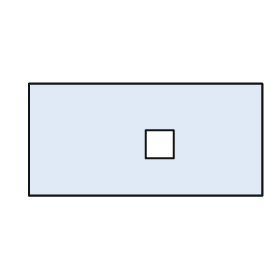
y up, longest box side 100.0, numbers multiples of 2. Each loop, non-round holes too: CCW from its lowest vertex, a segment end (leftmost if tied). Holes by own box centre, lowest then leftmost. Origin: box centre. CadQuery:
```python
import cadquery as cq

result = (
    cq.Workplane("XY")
    .moveTo(-50.0, -24.0)
    .lineTo(50.0, -24.0)
    .lineTo(50.0, 24.0)
    .lineTo(-50.0, 24.0)
    .close()
    .moveTo(0.0, -8.0)
    .lineTo(12.0, -8.0)
    .lineTo(12.0, 4.0)
    .lineTo(0.0, 4.0)
    .close()
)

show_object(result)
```